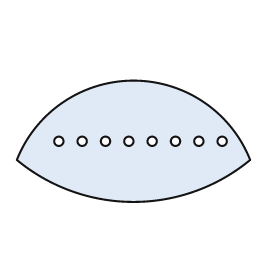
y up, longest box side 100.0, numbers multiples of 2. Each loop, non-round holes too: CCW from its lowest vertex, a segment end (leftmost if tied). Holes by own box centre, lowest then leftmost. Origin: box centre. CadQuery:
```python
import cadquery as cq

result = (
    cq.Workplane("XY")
    .moveTo(-50.0, -8.0)
    .threePointArc((0.0, -26.0), (50.0, -8.0))
    .threePointArc((0.0, 26.0), (-50.0, -8.0))
    .close()
    .moveTo(-32.0, 0.0)
    .circle(2.0)
    .moveTo(-22.0, 0.0)
    .circle(2.0)
    .moveTo(-12.0, 0.0)
    .circle(2.0)
    .moveTo(-2.0, 0.0)
    .circle(2.0)
    .moveTo(8.0, 0.0)
    .circle(2.0)
    .moveTo(18.0, 0.0)
    .circle(2.0)
    .moveTo(28.0, 0.0)
    .circle(2.0)
    .moveTo(38.0, 0.0)
    .circle(2.0)
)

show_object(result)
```